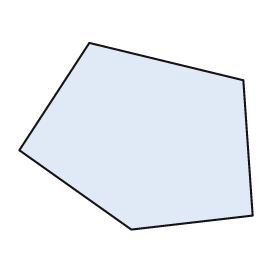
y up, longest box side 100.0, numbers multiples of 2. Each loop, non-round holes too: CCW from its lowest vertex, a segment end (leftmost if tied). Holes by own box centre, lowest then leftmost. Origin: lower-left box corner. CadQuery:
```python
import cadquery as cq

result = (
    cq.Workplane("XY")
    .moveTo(48.0, 0.0)
    .lineTo(100.0, 6.0)
    .lineTo(96.0, 64.0)
    .lineTo(30.0, 80.0)
    .lineTo(0.0, 34.0)
    .close()
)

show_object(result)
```